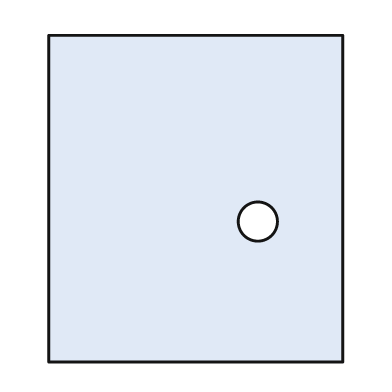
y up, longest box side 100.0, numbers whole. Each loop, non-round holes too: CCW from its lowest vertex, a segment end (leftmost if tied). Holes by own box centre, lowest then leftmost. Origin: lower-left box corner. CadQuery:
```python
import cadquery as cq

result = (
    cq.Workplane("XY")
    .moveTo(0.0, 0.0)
    .lineTo(90.0, 0.0)
    .lineTo(90.0, 100.0)
    .lineTo(0.0, 100.0)
    .close()
    .moveTo(64.0, 43.0)
    .circle(6.0)
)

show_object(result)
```